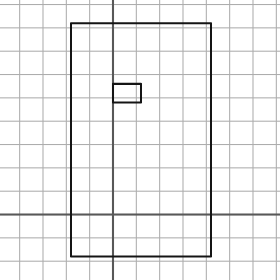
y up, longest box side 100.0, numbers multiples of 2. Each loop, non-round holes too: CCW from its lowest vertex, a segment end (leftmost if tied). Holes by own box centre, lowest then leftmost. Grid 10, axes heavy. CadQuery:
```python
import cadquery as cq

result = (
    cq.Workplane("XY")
    .moveTo(-18.0, -18.0)
    .lineTo(42.0, -18.0)
    .lineTo(42.0, 82.0)
    .lineTo(-18.0, 82.0)
    .close()
    .moveTo(0.0, 48.0)
    .lineTo(12.0, 48.0)
    .lineTo(12.0, 56.0)
    .lineTo(0.0, 56.0)
    .close()
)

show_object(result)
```